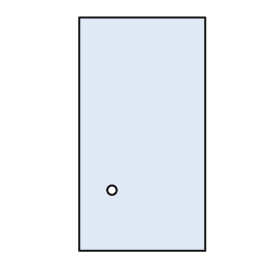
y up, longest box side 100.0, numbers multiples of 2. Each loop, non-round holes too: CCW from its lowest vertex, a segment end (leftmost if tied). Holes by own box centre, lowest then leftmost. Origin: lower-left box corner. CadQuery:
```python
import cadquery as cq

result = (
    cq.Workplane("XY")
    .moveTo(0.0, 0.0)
    .lineTo(54.0, 0.0)
    .lineTo(54.0, 100.0)
    .lineTo(0.0, 100.0)
    .close()
    .moveTo(14.0, 26.0)
    .circle(2.0)
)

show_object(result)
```